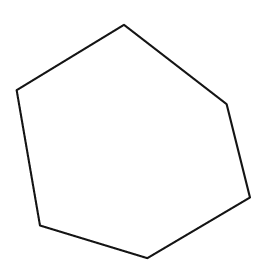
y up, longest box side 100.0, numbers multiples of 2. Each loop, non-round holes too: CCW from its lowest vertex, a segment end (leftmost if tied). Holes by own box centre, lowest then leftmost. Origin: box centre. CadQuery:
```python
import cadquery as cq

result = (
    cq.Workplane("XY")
    .moveTo(6.0, -50.0)
    .lineTo(50.0, -24.0)
    .lineTo(40.0, 16.0)
    .lineTo(-4.0, 50.0)
    .lineTo(-50.0, 22.0)
    .lineTo(-40.0, -36.0)
    .close()
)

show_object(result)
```